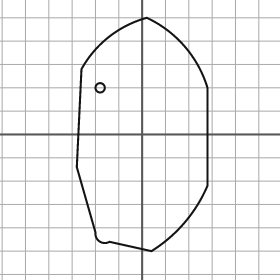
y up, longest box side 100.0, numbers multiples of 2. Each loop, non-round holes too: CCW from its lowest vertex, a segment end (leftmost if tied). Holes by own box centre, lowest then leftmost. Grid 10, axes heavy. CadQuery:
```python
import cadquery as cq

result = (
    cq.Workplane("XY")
    .moveTo(4.0, -50.0)
    .threePointArc((18.0, -38.0), (28.0, -22.0))
    .lineTo(28.0, 20.0)
    .threePointArc((18.0, 38.0), (2.0, 50.0))
    .threePointArc((-14.0, 42.0), (-26.0, 28.0))
    .lineTo(-28.0, -14.0)
    .lineTo(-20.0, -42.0)
    .threePointArc((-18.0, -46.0), (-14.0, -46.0))
    .close()
    .moveTo(-18.0, 20.0)
    .circle(2.0)
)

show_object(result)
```